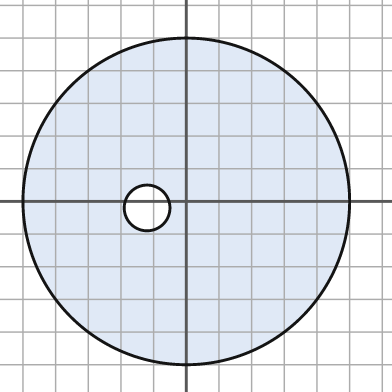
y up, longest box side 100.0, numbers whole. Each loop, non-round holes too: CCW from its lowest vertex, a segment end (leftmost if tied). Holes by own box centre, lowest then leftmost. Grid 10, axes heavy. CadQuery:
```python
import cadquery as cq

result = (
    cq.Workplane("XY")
    .moveTo(0.0, 0.0)
    .circle(50.0)
    .moveTo(-12.0, -2.0)
    .circle(7.0)
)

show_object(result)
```